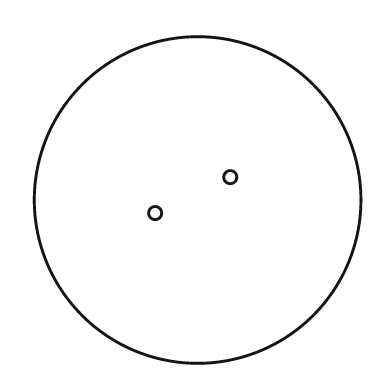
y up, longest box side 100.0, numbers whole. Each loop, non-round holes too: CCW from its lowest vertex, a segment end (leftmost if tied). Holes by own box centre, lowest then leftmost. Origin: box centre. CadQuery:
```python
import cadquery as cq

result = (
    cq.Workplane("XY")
    .moveTo(0.0, 0.0)
    .circle(50.0)
    .moveTo(-13.0, -4.0)
    .circle(2.0)
    .moveTo(10.0, 7.0)
    .circle(2.0)
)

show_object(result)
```